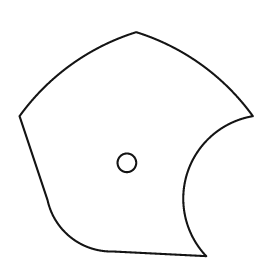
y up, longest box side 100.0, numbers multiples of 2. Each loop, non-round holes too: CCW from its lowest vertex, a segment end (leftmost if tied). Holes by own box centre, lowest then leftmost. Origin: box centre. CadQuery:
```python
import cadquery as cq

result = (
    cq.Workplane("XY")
    .moveTo(30.0, -48.0)
    .threePointArc((22.0, -12.0), (50.0, 12.0))
    .threePointArc((28.0, 34.0), (0.0, 48.0))
    .threePointArc((-28.0, 34.0), (-50.0, 12.0))
    .lineTo(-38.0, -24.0)
    .threePointArc((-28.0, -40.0), (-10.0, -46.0))
    .close()
    .moveTo(-4.0, -8.0)
    .circle(4.0)
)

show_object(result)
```